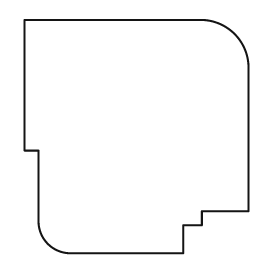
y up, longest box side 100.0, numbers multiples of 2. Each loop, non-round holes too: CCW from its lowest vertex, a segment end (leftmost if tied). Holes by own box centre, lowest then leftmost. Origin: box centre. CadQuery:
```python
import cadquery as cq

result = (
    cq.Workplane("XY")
    .moveTo(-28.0, -50.0)
    .lineTo(20.0, -50.0)
    .lineTo(20.0, -38.0)
    .lineTo(28.0, -38.0)
    .lineTo(28.0, -32.0)
    .lineTo(48.0, -32.0)
    .lineTo(48.0, 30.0)
    .threePointArc((42.0, 44.0), (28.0, 50.0))
    .lineTo(-48.0, 50.0)
    .lineTo(-48.0, -6.0)
    .lineTo(-42.0, -6.0)
    .lineTo(-42.0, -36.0)
    .threePointArc((-38.0, -46.0), (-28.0, -50.0))
    .close()
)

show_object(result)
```